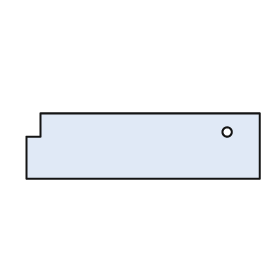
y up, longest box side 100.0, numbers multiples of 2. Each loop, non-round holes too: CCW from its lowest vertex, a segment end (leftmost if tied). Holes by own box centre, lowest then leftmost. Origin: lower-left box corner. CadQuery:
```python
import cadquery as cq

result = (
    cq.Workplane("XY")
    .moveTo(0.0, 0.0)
    .lineTo(100.0, 0.0)
    .lineTo(100.0, 28.0)
    .lineTo(6.0, 28.0)
    .lineTo(6.0, 18.0)
    .lineTo(0.0, 18.0)
    .close()
    .moveTo(86.0, 20.0)
    .circle(2.0)
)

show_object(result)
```